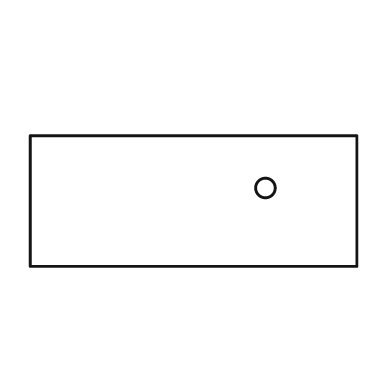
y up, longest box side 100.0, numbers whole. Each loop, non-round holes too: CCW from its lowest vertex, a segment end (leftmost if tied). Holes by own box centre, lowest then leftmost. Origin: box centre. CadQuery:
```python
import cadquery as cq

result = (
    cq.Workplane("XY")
    .moveTo(-50.0, -20.0)
    .lineTo(50.0, -20.0)
    .lineTo(50.0, 20.0)
    .lineTo(-50.0, 20.0)
    .close()
    .moveTo(22.0, 4.0)
    .circle(3.0)
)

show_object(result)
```